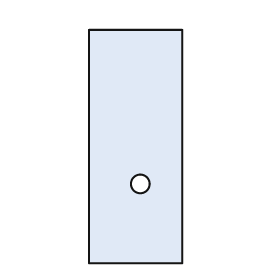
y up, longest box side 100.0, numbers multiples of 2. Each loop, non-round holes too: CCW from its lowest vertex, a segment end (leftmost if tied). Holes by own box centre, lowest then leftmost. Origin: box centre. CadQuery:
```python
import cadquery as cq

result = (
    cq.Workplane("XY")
    .moveTo(-20.0, -50.0)
    .lineTo(20.0, -50.0)
    .lineTo(20.0, 50.0)
    .lineTo(-20.0, 50.0)
    .close()
    .moveTo(2.0, -16.0)
    .circle(4.0)
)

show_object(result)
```